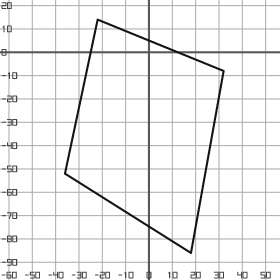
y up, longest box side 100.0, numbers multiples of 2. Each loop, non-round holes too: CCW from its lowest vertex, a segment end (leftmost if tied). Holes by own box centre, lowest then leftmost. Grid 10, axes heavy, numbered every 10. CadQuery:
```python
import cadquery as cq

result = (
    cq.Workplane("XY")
    .moveTo(18.0, -86.0)
    .lineTo(32.0, -8.0)
    .lineTo(-22.0, 14.0)
    .lineTo(-36.0, -52.0)
    .close()
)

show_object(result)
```